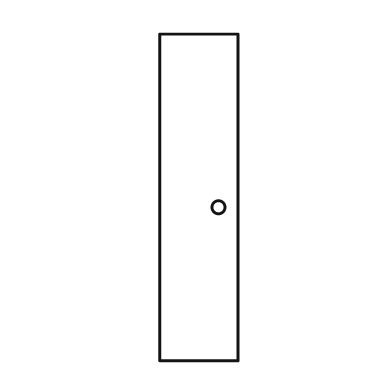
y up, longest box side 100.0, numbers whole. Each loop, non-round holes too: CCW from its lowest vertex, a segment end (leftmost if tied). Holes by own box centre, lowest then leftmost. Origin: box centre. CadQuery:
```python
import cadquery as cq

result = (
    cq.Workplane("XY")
    .moveTo(-12.0, -50.0)
    .lineTo(12.0, -50.0)
    .lineTo(12.0, 50.0)
    .lineTo(-12.0, 50.0)
    .close()
    .moveTo(6.0, -3.0)
    .circle(2.0)
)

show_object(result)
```